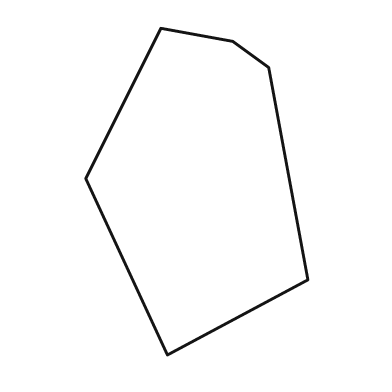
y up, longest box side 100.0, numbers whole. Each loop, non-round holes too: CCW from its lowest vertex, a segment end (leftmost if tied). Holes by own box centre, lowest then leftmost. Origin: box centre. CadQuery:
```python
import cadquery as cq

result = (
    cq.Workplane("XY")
    .moveTo(-9.0, -50.0)
    .lineTo(34.0, -27.0)
    .lineTo(22.0, 38.0)
    .lineTo(11.0, 46.0)
    .lineTo(-11.0, 50.0)
    .lineTo(-34.0, 4.0)
    .close()
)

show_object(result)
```